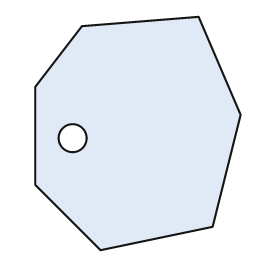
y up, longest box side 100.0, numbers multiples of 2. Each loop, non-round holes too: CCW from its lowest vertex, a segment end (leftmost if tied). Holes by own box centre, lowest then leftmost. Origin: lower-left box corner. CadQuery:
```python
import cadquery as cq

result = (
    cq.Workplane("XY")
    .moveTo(28.0, 0.0)
    .lineTo(76.0, 10.0)
    .lineTo(88.0, 58.0)
    .lineTo(70.0, 100.0)
    .lineTo(20.0, 96.0)
    .lineTo(0.0, 70.0)
    .lineTo(0.0, 28.0)
    .close()
    .moveTo(16.0, 48.0)
    .circle(6.0)
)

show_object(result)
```